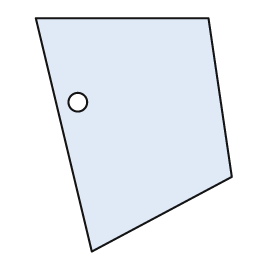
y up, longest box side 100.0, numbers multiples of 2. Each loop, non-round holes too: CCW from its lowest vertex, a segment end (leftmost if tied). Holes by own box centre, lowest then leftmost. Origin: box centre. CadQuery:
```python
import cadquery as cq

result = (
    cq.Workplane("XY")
    .moveTo(-18.0, -50.0)
    .lineTo(42.0, -18.0)
    .lineTo(32.0, 50.0)
    .lineTo(-42.0, 50.0)
    .close()
    .moveTo(-24.0, 14.0)
    .circle(4.0)
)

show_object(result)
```